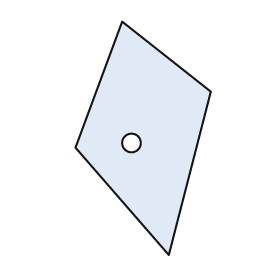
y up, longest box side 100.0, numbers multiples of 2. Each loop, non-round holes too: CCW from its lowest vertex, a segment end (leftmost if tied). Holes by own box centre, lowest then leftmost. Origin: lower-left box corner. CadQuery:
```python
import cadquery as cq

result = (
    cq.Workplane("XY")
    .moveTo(40.0, 0.0)
    .lineTo(58.0, 70.0)
    .lineTo(20.0, 100.0)
    .lineTo(0.0, 46.0)
    .close()
    .moveTo(24.0, 48.0)
    .circle(4.0)
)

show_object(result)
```